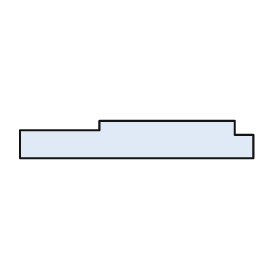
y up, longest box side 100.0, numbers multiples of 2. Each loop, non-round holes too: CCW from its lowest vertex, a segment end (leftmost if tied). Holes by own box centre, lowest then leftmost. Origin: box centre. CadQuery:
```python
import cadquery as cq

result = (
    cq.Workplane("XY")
    .moveTo(-50.0, -8.0)
    .lineTo(50.0, -8.0)
    .lineTo(50.0, 2.0)
    .lineTo(42.0, 2.0)
    .lineTo(42.0, 8.0)
    .lineTo(-16.0, 8.0)
    .lineTo(-16.0, 4.0)
    .lineTo(-50.0, 4.0)
    .close()
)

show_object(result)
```